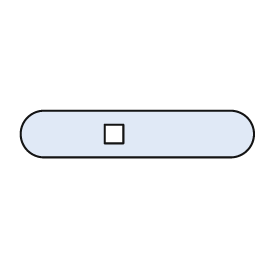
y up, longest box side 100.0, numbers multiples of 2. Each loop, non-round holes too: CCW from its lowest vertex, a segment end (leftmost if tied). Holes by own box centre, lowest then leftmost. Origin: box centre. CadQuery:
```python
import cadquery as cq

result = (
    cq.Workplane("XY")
    .moveTo(-40.0, -10.0)
    .lineTo(40.0, -10.0)
    .threePointArc((50.0, 0.0), (40.0, 10.0))
    .lineTo(-40.0, 10.0)
    .threePointArc((-50.0, 0.0), (-40.0, -10.0))
    .close()
    .moveTo(-14.0, -4.0)
    .lineTo(-6.0, -4.0)
    .lineTo(-6.0, 4.0)
    .lineTo(-14.0, 4.0)
    .close()
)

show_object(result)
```